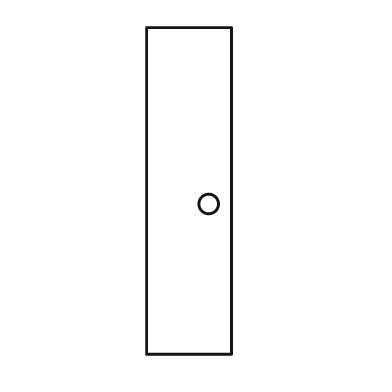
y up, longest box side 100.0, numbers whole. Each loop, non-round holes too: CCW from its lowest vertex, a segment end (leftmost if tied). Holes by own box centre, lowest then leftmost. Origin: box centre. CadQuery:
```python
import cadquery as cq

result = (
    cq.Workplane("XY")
    .moveTo(-13.0, -50.0)
    .lineTo(13.0, -50.0)
    .lineTo(13.0, 50.0)
    .lineTo(-13.0, 50.0)
    .close()
    .moveTo(6.0, -4.0)
    .circle(3.0)
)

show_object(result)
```